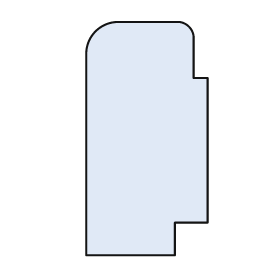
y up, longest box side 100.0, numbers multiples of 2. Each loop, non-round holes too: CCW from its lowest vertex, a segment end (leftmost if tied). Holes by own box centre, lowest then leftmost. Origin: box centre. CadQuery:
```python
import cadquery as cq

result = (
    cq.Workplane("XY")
    .moveTo(-26.0, -50.0)
    .lineTo(12.0, -50.0)
    .lineTo(12.0, -36.0)
    .lineTo(26.0, -36.0)
    .lineTo(26.0, 26.0)
    .lineTo(20.0, 26.0)
    .lineTo(20.0, 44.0)
    .threePointArc((18.0, 48.0), (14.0, 50.0))
    .lineTo(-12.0, 50.0)
    .threePointArc((-22.0, 46.0), (-26.0, 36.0))
    .close()
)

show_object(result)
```